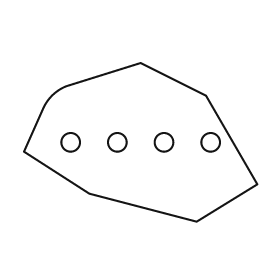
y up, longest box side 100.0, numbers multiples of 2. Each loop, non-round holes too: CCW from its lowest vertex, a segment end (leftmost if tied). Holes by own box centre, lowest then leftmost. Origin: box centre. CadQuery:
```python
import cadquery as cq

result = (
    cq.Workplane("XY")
    .moveTo(24.0, -34.0)
    .lineTo(50.0, -18.0)
    .lineTo(28.0, 20.0)
    .lineTo(0.0, 34.0)
    .lineTo(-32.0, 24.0)
    .threePointArc((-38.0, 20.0), (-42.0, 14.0))
    .lineTo(-50.0, -4.0)
    .lineTo(-22.0, -22.0)
    .close()
    .moveTo(-30.0, 0.0)
    .circle(4.0)
    .moveTo(-10.0, 0.0)
    .circle(4.0)
    .moveTo(10.0, 0.0)
    .circle(4.0)
    .moveTo(30.0, 0.0)
    .circle(4.0)
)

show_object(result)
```